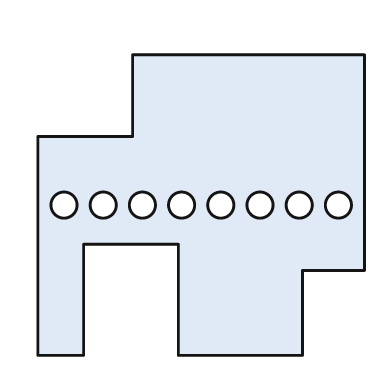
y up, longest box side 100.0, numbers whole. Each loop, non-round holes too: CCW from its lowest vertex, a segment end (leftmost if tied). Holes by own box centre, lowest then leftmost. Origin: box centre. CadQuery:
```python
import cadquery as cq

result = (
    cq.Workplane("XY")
    .moveTo(-50.0, -46.0)
    .lineTo(-36.0, -46.0)
    .lineTo(-36.0, -12.0)
    .lineTo(-7.0, -12.0)
    .lineTo(-7.0, -46.0)
    .lineTo(31.0, -46.0)
    .lineTo(31.0, -20.0)
    .lineTo(50.0, -20.0)
    .lineTo(50.0, 46.0)
    .lineTo(-21.0, 46.0)
    .lineTo(-21.0, 21.0)
    .lineTo(-50.0, 21.0)
    .close()
    .moveTo(-42.0, 0.0)
    .circle(4.0)
    .moveTo(-30.0, 0.0)
    .circle(4.0)
    .moveTo(-18.0, 0.0)
    .circle(4.0)
    .moveTo(-6.0, 0.0)
    .circle(4.0)
    .moveTo(6.0, 0.0)
    .circle(4.0)
    .moveTo(18.0, 0.0)
    .circle(4.0)
    .moveTo(30.0, 0.0)
    .circle(4.0)
    .moveTo(42.0, 0.0)
    .circle(4.0)
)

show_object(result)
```